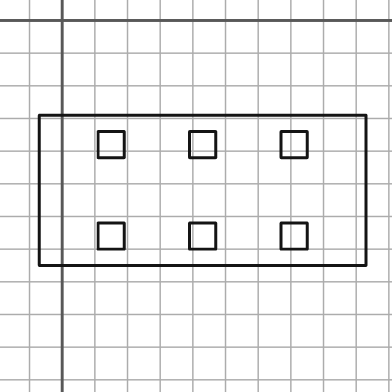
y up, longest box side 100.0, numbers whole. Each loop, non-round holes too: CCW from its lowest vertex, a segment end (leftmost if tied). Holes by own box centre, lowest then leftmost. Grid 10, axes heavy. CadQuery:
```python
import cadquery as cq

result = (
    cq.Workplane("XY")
    .moveTo(-7.0, -75.0)
    .lineTo(93.0, -75.0)
    .lineTo(93.0, -29.0)
    .lineTo(-7.0, -29.0)
    .close()
    .moveTo(11.0, -70.0)
    .lineTo(19.0, -70.0)
    .lineTo(19.0, -62.0)
    .lineTo(11.0, -62.0)
    .close()
    .moveTo(39.0, -70.0)
    .lineTo(47.0, -70.0)
    .lineTo(47.0, -62.0)
    .lineTo(39.0, -62.0)
    .close()
    .moveTo(67.0, -70.0)
    .lineTo(75.0, -70.0)
    .lineTo(75.0, -62.0)
    .lineTo(67.0, -62.0)
    .close()
    .moveTo(11.0, -42.0)
    .lineTo(19.0, -42.0)
    .lineTo(19.0, -34.0)
    .lineTo(11.0, -34.0)
    .close()
    .moveTo(39.0, -42.0)
    .lineTo(47.0, -42.0)
    .lineTo(47.0, -34.0)
    .lineTo(39.0, -34.0)
    .close()
    .moveTo(67.0, -42.0)
    .lineTo(75.0, -42.0)
    .lineTo(75.0, -34.0)
    .lineTo(67.0, -34.0)
    .close()
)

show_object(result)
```